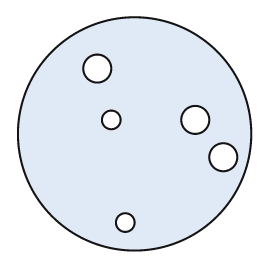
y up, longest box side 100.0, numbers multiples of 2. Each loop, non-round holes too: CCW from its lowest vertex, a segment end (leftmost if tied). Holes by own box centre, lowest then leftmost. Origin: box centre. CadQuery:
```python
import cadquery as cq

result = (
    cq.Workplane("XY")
    .moveTo(0.0, 0.0)
    .circle(50.0)
    .moveTo(-4.0, -38.0)
    .circle(4.0)
    .moveTo(38.0, -10.0)
    .circle(6.0)
    .moveTo(-10.0, 6.0)
    .circle(4.0)
    .moveTo(26.0, 6.0)
    .circle(6.0)
    .moveTo(-16.0, 28.0)
    .circle(6.0)
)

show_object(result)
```